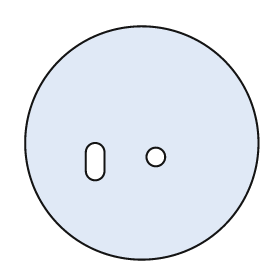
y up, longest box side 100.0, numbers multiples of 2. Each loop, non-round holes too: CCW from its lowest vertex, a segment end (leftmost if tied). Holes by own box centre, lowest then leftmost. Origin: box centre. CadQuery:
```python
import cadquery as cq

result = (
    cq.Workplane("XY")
    .moveTo(0.0, 0.0)
    .circle(50.0)
    .moveTo(-24.0, -12.0)
    .threePointArc((-20.0, -16.0), (-16.0, -12.0))
    .lineTo(-16.0, -4.0)
    .threePointArc((-20.0, 0.0), (-24.0, -4.0))
    .close()
    .moveTo(6.0, -6.0)
    .circle(4.0)
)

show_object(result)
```